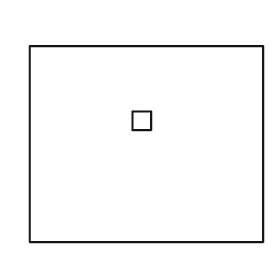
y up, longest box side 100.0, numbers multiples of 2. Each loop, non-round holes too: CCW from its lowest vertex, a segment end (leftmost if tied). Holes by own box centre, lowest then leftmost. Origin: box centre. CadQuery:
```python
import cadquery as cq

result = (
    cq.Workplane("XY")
    .moveTo(-50.0, -42.0)
    .lineTo(50.0, -42.0)
    .lineTo(50.0, 42.0)
    .lineTo(-50.0, 42.0)
    .close()
    .moveTo(-6.0, 6.0)
    .lineTo(2.0, 6.0)
    .lineTo(2.0, 14.0)
    .lineTo(-6.0, 14.0)
    .close()
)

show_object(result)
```